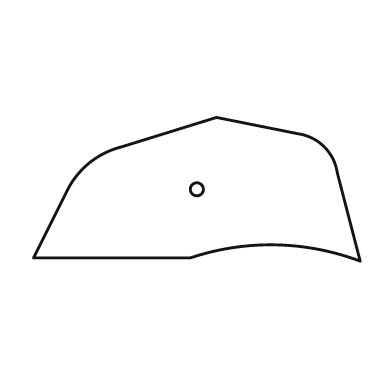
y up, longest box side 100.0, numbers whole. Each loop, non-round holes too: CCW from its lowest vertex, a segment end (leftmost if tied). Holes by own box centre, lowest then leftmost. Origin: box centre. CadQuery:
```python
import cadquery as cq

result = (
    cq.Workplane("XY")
    .moveTo(50.0, -22.0)
    .lineTo(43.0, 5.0)
    .threePointArc((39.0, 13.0), (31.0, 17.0))
    .lineTo(6.0, 22.0)
    .lineTo(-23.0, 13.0)
    .threePointArc((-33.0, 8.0), (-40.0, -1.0))
    .lineTo(-50.0, -21.0)
    .lineTo(-2.0, -21.0)
    .threePointArc((24.0, -17.0), (50.0, -22.0))
    .close()
    .moveTo(0.0, 0.0)
    .circle(2.0)
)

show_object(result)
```